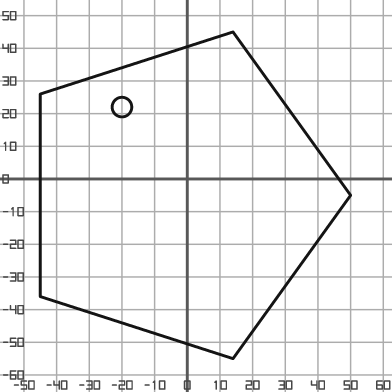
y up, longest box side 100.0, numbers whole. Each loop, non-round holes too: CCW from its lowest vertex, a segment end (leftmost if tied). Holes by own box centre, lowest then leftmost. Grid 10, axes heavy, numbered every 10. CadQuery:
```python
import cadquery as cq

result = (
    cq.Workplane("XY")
    .moveTo(14.0, -55.0)
    .lineTo(50.0, -5.0)
    .lineTo(14.0, 45.0)
    .lineTo(-45.0, 26.0)
    .lineTo(-45.0, -36.0)
    .close()
    .moveTo(-20.0, 22.0)
    .circle(3.0)
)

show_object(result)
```